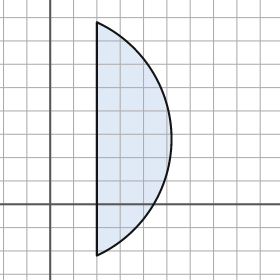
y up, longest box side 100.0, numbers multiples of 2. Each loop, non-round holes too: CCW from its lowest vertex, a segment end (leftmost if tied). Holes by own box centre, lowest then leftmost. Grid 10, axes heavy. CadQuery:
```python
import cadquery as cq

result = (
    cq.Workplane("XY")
    .moveTo(20.0, -22.0)
    .threePointArc((52.0, 28.0), (20.0, 78.0))
    .close()
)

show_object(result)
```